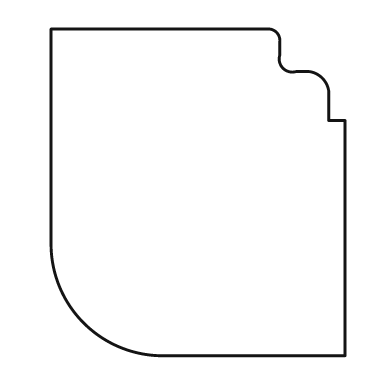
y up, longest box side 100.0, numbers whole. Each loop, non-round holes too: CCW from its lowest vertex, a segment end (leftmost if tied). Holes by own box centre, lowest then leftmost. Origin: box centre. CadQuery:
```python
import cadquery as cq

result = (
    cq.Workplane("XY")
    .moveTo(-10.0, -50.0)
    .lineTo(45.0, -50.0)
    .lineTo(45.0, 22.0)
    .lineTo(40.0, 22.0)
    .lineTo(40.0, 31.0)
    .threePointArc((38.0, 35.0), (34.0, 37.0))
    .lineTo(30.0, 37.0)
    .threePointArc((26.0, 38.0), (25.0, 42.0))
    .lineTo(25.0, 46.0)
    .threePointArc((24.0, 49.0), (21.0, 50.0))
    .lineTo(-45.0, 50.0)
    .lineTo(-45.0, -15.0)
    .threePointArc((-35.0, -40.0), (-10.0, -50.0))
    .close()
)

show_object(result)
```